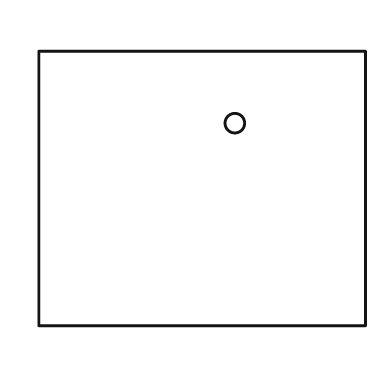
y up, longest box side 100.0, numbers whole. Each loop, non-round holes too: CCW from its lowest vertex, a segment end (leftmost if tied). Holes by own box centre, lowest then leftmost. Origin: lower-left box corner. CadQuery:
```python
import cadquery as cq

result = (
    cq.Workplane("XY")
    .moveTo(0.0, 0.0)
    .lineTo(100.0, 0.0)
    .lineTo(100.0, 84.0)
    .lineTo(0.0, 84.0)
    .close()
    .moveTo(60.0, 62.0)
    .circle(3.0)
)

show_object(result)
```